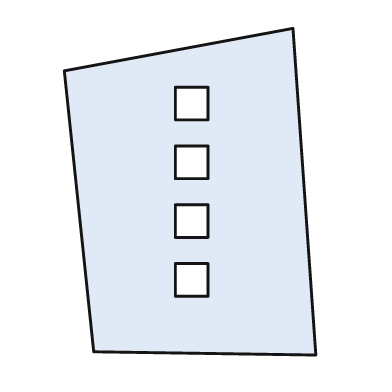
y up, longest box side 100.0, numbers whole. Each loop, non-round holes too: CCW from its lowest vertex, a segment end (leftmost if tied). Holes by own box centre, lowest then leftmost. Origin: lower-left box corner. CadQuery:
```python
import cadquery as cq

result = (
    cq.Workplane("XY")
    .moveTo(77.0, 0.0)
    .lineTo(70.0, 100.0)
    .lineTo(0.0, 87.0)
    .lineTo(9.0, 1.0)
    .close()
    .moveTo(34.0, 18.0)
    .lineTo(44.0, 18.0)
    .lineTo(44.0, 28.0)
    .lineTo(34.0, 28.0)
    .close()
    .moveTo(34.0, 36.0)
    .lineTo(44.0, 36.0)
    .lineTo(44.0, 46.0)
    .lineTo(34.0, 46.0)
    .close()
    .moveTo(34.0, 54.0)
    .lineTo(44.0, 54.0)
    .lineTo(44.0, 64.0)
    .lineTo(34.0, 64.0)
    .close()
    .moveTo(34.0, 72.0)
    .lineTo(44.0, 72.0)
    .lineTo(44.0, 82.0)
    .lineTo(34.0, 82.0)
    .close()
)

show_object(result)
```